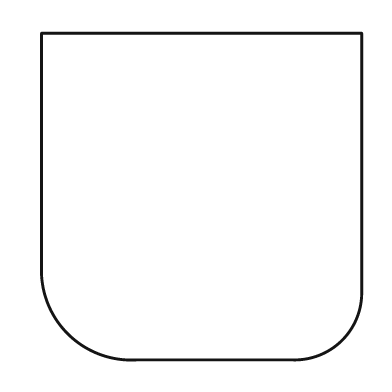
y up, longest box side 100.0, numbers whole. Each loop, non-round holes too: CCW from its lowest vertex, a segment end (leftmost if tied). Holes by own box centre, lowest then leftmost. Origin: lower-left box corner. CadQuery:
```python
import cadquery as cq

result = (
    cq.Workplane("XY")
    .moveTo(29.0, 0.0)
    .lineTo(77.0, 0.0)
    .threePointArc((92.0, 6.0), (98.0, 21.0))
    .lineTo(98.0, 100.0)
    .lineTo(0.0, 100.0)
    .lineTo(0.0, 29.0)
    .threePointArc((8.0, 8.0), (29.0, 0.0))
    .close()
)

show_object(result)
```